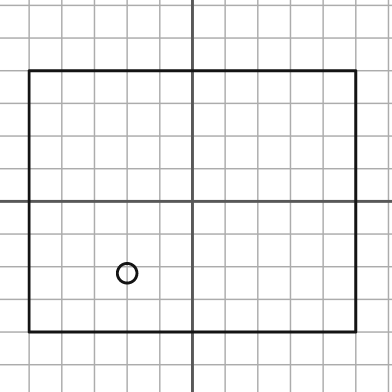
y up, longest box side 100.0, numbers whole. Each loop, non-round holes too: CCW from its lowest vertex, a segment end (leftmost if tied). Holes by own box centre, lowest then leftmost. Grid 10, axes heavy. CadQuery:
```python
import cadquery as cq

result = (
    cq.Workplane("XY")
    .moveTo(-50.0, -40.0)
    .lineTo(50.0, -40.0)
    .lineTo(50.0, 40.0)
    .lineTo(-50.0, 40.0)
    .close()
    .moveTo(-20.0, -22.0)
    .circle(3.0)
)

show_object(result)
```